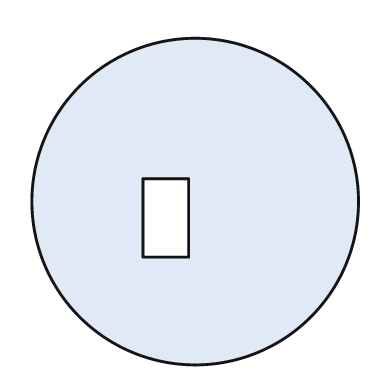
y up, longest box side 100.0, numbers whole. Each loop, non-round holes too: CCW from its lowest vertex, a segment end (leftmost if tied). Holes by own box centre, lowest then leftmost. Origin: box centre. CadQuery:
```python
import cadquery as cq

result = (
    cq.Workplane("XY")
    .moveTo(0.0, 0.0)
    .circle(50.0)
    .moveTo(-16.0, -17.0)
    .lineTo(-2.0, -17.0)
    .lineTo(-2.0, 7.0)
    .lineTo(-16.0, 7.0)
    .close()
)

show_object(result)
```